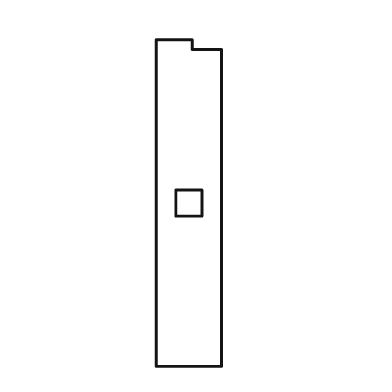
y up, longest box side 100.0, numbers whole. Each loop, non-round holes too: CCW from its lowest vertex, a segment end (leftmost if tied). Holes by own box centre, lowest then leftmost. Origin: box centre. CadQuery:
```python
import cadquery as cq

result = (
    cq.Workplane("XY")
    .moveTo(-10.0, -50.0)
    .lineTo(10.0, -50.0)
    .lineTo(10.0, 47.0)
    .lineTo(1.0, 47.0)
    .lineTo(1.0, 50.0)
    .lineTo(-10.0, 50.0)
    .close()
    .moveTo(-4.0, -4.0)
    .lineTo(4.0, -4.0)
    .lineTo(4.0, 4.0)
    .lineTo(-4.0, 4.0)
    .close()
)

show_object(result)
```